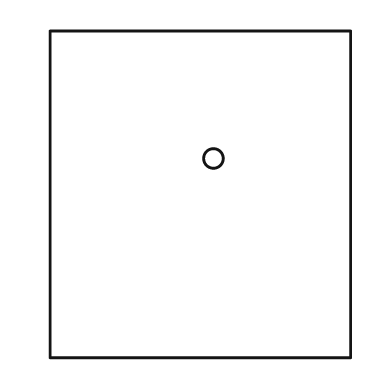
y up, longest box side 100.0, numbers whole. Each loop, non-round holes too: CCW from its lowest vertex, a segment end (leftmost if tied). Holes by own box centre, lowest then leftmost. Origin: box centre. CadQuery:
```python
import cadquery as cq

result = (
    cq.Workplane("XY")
    .moveTo(-46.0, -50.0)
    .lineTo(46.0, -50.0)
    .lineTo(46.0, 50.0)
    .lineTo(-46.0, 50.0)
    .close()
    .moveTo(4.0, 11.0)
    .circle(3.0)
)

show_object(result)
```